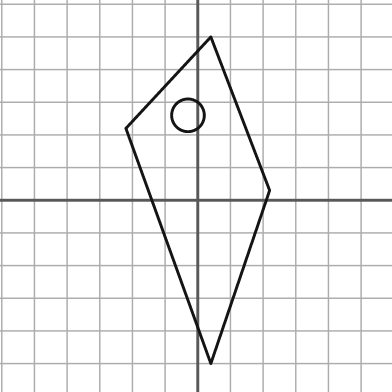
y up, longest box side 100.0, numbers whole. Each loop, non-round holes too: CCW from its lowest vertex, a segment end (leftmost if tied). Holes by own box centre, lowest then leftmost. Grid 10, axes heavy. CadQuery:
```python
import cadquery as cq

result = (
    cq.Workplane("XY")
    .moveTo(4.0, -50.0)
    .lineTo(22.0, 3.0)
    .lineTo(4.0, 50.0)
    .lineTo(-22.0, 22.0)
    .close()
    .moveTo(-3.0, 26.0)
    .circle(5.0)
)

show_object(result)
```